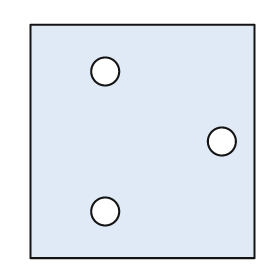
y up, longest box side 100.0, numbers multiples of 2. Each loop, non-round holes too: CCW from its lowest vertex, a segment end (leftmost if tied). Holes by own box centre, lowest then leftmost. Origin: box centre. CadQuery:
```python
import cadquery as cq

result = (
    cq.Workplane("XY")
    .moveTo(-48.0, -50.0)
    .lineTo(48.0, -50.0)
    .lineTo(48.0, 50.0)
    .lineTo(-48.0, 50.0)
    .close()
    .moveTo(-16.0, -30.0)
    .circle(6.0)
    .moveTo(34.0, 0.0)
    .circle(6.0)
    .moveTo(-16.0, 30.0)
    .circle(6.0)
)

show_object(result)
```